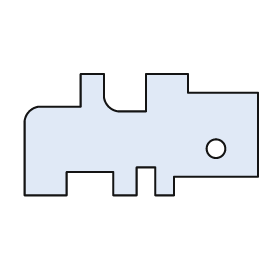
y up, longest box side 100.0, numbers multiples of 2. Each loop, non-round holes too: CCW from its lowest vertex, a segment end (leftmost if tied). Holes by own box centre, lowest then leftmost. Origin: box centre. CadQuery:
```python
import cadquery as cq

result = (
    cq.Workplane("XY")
    .moveTo(-50.0, -26.0)
    .lineTo(-32.0, -26.0)
    .lineTo(-32.0, -16.0)
    .lineTo(-12.0, -16.0)
    .lineTo(-12.0, -26.0)
    .lineTo(-2.0, -26.0)
    .lineTo(-2.0, -14.0)
    .lineTo(6.0, -14.0)
    .lineTo(6.0, -26.0)
    .lineTo(14.0, -26.0)
    .lineTo(14.0, -18.0)
    .lineTo(50.0, -18.0)
    .lineTo(50.0, 18.0)
    .lineTo(20.0, 18.0)
    .lineTo(20.0, 26.0)
    .lineTo(2.0, 26.0)
    .lineTo(2.0, 10.0)
    .lineTo(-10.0, 10.0)
    .threePointArc((-14.0, 12.0), (-16.0, 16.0))
    .lineTo(-16.0, 26.0)
    .lineTo(-26.0, 26.0)
    .lineTo(-26.0, 12.0)
    .lineTo(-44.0, 12.0)
    .threePointArc((-48.0, 10.0), (-50.0, 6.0))
    .close()
    .moveTo(32.0, -6.0)
    .circle(4.0)
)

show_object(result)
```